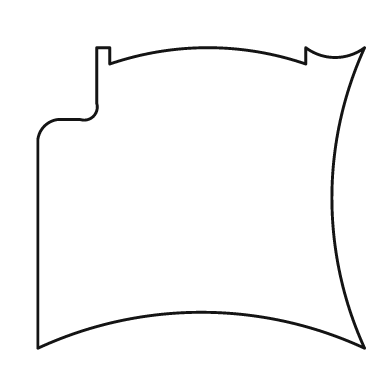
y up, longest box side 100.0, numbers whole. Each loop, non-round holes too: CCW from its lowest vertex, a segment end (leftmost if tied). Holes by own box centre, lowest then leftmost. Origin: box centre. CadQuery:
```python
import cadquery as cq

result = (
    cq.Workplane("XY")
    .moveTo(-50.0, -46.0)
    .threePointArc((0.0, -35.0), (50.0, -46.0))
    .threePointArc((40.0, 0.0), (50.0, 46.0))
    .threePointArc((41.0, 43.0), (32.0, 46.0))
    .lineTo(32.0, 41.0)
    .threePointArc((2.0, 46.0), (-28.0, 41.0))
    .lineTo(-28.0, 46.0)
    .lineTo(-32.0, 46.0)
    .lineTo(-32.0, 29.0)
    .threePointArc((-33.0, 25.0), (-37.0, 24.0))
    .lineTo(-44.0, 24.0)
    .threePointArc((-48.0, 22.0), (-50.0, 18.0))
    .close()
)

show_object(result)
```